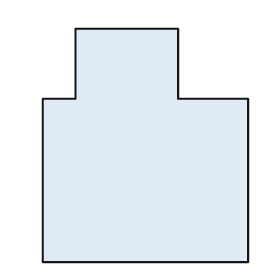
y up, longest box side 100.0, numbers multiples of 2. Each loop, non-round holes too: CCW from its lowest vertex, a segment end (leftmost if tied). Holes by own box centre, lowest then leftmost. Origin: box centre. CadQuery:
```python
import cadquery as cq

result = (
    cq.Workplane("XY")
    .moveTo(-44.0, -50.0)
    .lineTo(44.0, -50.0)
    .lineTo(44.0, 20.0)
    .lineTo(14.0, 20.0)
    .lineTo(14.0, 50.0)
    .lineTo(-30.0, 50.0)
    .lineTo(-30.0, 20.0)
    .lineTo(-44.0, 20.0)
    .close()
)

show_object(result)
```